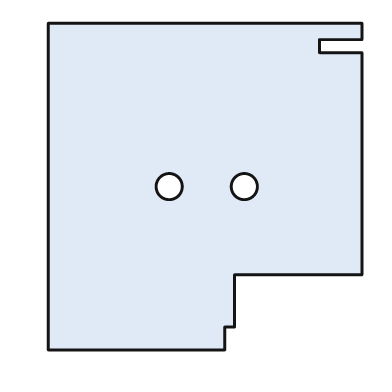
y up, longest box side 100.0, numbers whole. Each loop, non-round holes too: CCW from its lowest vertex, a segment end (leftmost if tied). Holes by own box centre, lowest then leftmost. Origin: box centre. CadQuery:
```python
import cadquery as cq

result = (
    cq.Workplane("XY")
    .moveTo(-48.0, -50.0)
    .lineTo(6.0, -50.0)
    .lineTo(6.0, -43.0)
    .lineTo(9.0, -43.0)
    .lineTo(9.0, -27.0)
    .lineTo(48.0, -27.0)
    .lineTo(48.0, 41.0)
    .lineTo(35.0, 41.0)
    .lineTo(35.0, 45.0)
    .lineTo(48.0, 45.0)
    .lineTo(48.0, 50.0)
    .lineTo(-48.0, 50.0)
    .close()
    .moveTo(-11.0, 0.0)
    .circle(4.0)
    .moveTo(12.0, 0.0)
    .circle(4.0)
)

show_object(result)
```